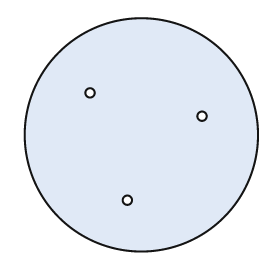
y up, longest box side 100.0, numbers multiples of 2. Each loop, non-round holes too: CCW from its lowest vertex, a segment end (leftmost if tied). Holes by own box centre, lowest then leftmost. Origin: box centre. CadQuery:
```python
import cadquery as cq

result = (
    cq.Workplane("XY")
    .moveTo(0.0, 0.0)
    .circle(50.0)
    .moveTo(-6.0, -28.0)
    .circle(2.0)
    .moveTo(26.0, 8.0)
    .circle(2.0)
    .moveTo(-22.0, 18.0)
    .circle(2.0)
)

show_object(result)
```